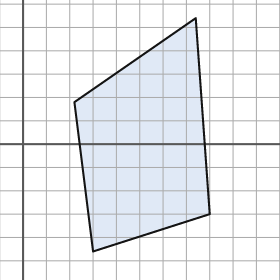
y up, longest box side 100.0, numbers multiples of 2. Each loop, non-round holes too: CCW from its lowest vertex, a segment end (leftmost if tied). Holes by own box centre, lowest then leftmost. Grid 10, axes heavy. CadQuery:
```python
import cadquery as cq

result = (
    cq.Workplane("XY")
    .moveTo(30.0, -46.0)
    .lineTo(80.0, -30.0)
    .lineTo(74.0, 54.0)
    .lineTo(22.0, 18.0)
    .close()
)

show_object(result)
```